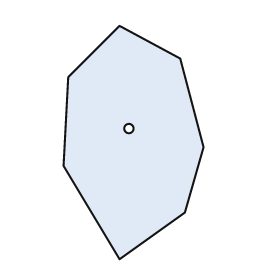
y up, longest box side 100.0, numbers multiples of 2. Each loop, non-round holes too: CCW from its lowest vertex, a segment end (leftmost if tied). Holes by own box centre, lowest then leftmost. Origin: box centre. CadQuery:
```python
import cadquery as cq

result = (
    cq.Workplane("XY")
    .moveTo(-6.0, -50.0)
    .lineTo(22.0, -30.0)
    .lineTo(30.0, -2.0)
    .lineTo(20.0, 36.0)
    .lineTo(-6.0, 50.0)
    .lineTo(-28.0, 28.0)
    .lineTo(-30.0, -10.0)
    .close()
    .moveTo(-2.0, 6.0)
    .circle(2.0)
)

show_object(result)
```